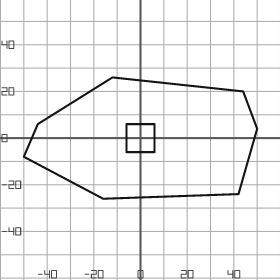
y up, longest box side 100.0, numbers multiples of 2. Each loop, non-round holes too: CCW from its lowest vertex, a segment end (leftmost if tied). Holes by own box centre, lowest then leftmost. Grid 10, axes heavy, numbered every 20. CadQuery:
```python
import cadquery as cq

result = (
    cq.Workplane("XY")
    .moveTo(-16.0, -26.0)
    .lineTo(42.0, -24.0)
    .lineTo(50.0, 4.0)
    .lineTo(44.0, 20.0)
    .lineTo(-12.0, 26.0)
    .lineTo(-44.0, 6.0)
    .lineTo(-50.0, -8.0)
    .close()
    .moveTo(-6.0, -6.0)
    .lineTo(6.0, -6.0)
    .lineTo(6.0, 6.0)
    .lineTo(-6.0, 6.0)
    .close()
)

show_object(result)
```